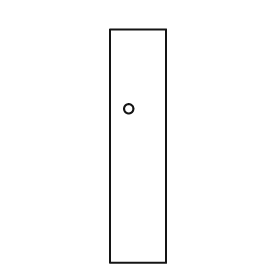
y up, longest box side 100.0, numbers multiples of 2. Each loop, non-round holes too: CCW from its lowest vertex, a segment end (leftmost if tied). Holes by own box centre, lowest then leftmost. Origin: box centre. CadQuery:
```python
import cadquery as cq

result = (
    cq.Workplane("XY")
    .moveTo(-12.0, -50.0)
    .lineTo(12.0, -50.0)
    .lineTo(12.0, 50.0)
    .lineTo(-12.0, 50.0)
    .close()
    .moveTo(-4.0, 16.0)
    .circle(2.0)
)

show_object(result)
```